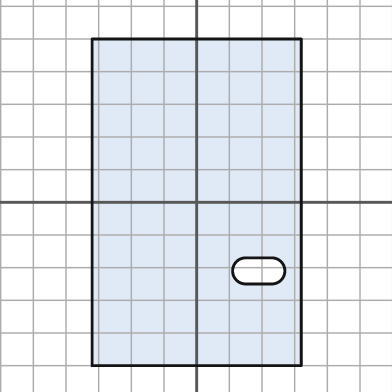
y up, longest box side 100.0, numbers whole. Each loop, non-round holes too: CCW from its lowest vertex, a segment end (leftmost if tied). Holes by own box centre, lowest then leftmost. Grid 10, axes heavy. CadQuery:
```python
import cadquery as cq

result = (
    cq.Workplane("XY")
    .moveTo(-32.0, -50.0)
    .lineTo(32.0, -50.0)
    .lineTo(32.0, 50.0)
    .lineTo(-32.0, 50.0)
    .close()
    .moveTo(15.0, -25.0)
    .lineTo(23.0, -25.0)
    .threePointArc((27.0, -21.0), (23.0, -17.0))
    .lineTo(15.0, -17.0)
    .threePointArc((11.0, -21.0), (15.0, -25.0))
    .close()
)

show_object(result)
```